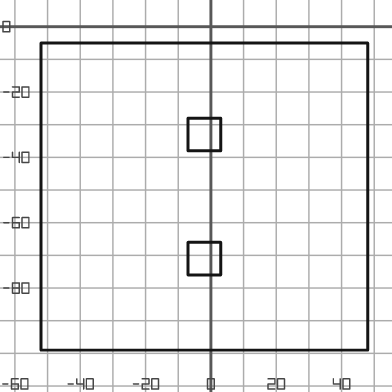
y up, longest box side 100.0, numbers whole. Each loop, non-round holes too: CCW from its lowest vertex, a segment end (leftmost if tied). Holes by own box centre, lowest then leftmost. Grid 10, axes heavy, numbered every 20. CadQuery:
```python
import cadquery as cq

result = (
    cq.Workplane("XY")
    .moveTo(-52.0, -99.0)
    .lineTo(48.0, -99.0)
    .lineTo(48.0, -5.0)
    .lineTo(-52.0, -5.0)
    .close()
    .moveTo(-7.0, -76.0)
    .lineTo(3.0, -76.0)
    .lineTo(3.0, -66.0)
    .lineTo(-7.0, -66.0)
    .close()
    .moveTo(-7.0, -38.0)
    .lineTo(3.0, -38.0)
    .lineTo(3.0, -28.0)
    .lineTo(-7.0, -28.0)
    .close()
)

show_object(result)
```